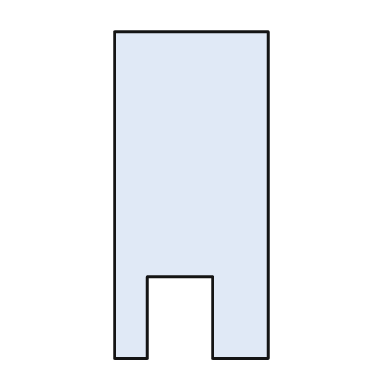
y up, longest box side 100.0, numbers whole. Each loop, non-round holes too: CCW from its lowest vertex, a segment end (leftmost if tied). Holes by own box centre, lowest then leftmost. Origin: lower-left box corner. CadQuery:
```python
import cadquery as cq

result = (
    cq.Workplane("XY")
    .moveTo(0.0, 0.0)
    .lineTo(10.0, 0.0)
    .lineTo(10.0, 25.0)
    .lineTo(30.0, 25.0)
    .lineTo(30.0, 0.0)
    .lineTo(47.0, 0.0)
    .lineTo(47.0, 100.0)
    .lineTo(0.0, 100.0)
    .close()
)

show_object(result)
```